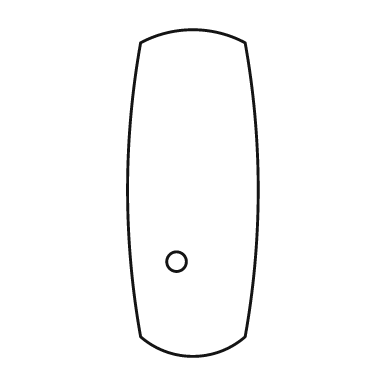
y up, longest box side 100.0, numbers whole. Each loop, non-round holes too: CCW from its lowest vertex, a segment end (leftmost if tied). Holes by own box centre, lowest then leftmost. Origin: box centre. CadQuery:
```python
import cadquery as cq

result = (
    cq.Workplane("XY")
    .moveTo(-16.0, -44.0)
    .threePointArc((0.0, -50.0), (16.0, -44.0))
    .threePointArc((20.0, 1.0), (16.0, 46.0))
    .threePointArc((0.0, 50.0), (-16.0, 46.0))
    .threePointArc((-20.0, 1.0), (-16.0, -44.0))
    .close()
    .moveTo(-5.0, -21.0)
    .circle(3.0)
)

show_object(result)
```